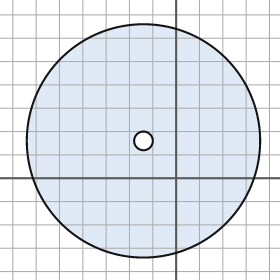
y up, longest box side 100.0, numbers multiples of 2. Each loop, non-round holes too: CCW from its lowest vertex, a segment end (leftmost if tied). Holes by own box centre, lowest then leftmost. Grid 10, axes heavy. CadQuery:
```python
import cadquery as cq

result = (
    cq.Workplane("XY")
    .moveTo(-14.0, 16.0)
    .circle(50.0)
    .moveTo(-14.0, 16.0)
    .circle(4.0)
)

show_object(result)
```